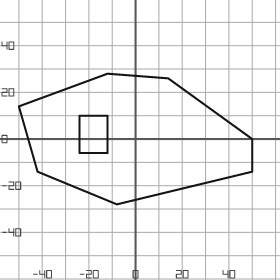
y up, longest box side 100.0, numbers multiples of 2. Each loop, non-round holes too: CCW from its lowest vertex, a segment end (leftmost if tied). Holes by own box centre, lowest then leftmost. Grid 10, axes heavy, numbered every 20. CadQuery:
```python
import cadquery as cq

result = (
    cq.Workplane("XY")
    .moveTo(-8.0, -28.0)
    .lineTo(50.0, -14.0)
    .lineTo(50.0, 0.0)
    .lineTo(14.0, 26.0)
    .lineTo(-12.0, 28.0)
    .lineTo(-50.0, 14.0)
    .lineTo(-42.0, -14.0)
    .close()
    .moveTo(-24.0, -6.0)
    .lineTo(-12.0, -6.0)
    .lineTo(-12.0, 10.0)
    .lineTo(-24.0, 10.0)
    .close()
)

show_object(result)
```